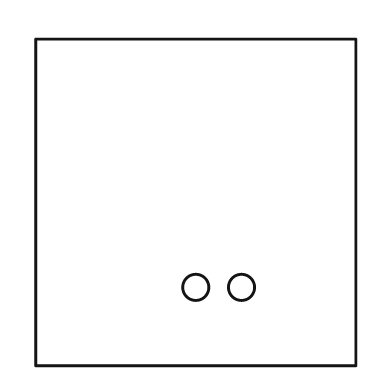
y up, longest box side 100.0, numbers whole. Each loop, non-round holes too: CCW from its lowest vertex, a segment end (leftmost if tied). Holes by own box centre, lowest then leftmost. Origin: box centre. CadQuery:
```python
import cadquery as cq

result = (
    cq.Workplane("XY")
    .moveTo(-49.0, -50.0)
    .lineTo(49.0, -50.0)
    .lineTo(49.0, 50.0)
    .lineTo(-49.0, 50.0)
    .close()
    .moveTo(0.0, -26.0)
    .circle(4.0)
    .moveTo(14.0, -26.0)
    .circle(4.0)
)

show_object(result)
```